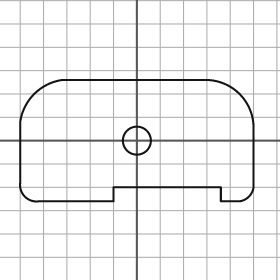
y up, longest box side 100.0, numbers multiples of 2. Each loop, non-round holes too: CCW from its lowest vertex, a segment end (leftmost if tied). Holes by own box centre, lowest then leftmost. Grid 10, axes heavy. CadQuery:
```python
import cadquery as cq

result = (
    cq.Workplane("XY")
    .moveTo(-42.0, -26.0)
    .lineTo(-10.0, -26.0)
    .lineTo(-10.0, -20.0)
    .lineTo(36.0, -20.0)
    .lineTo(36.0, -26.0)
    .lineTo(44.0, -26.0)
    .threePointArc((48.0, -24.0), (50.0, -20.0))
    .lineTo(50.0, 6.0)
    .threePointArc((44.0, 20.0), (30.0, 26.0))
    .lineTo(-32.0, 26.0)
    .threePointArc((-44.0, 20.0), (-50.0, 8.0))
    .lineTo(-50.0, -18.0)
    .threePointArc((-48.0, -24.0), (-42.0, -26.0))
    .close()
    .moveTo(0.0, 0.0)
    .circle(6.0)
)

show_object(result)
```